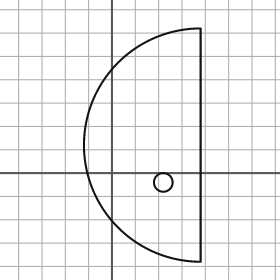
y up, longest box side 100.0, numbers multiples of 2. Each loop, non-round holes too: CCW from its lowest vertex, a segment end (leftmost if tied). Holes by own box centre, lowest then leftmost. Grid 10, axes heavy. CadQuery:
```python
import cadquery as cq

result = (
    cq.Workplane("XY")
    .moveTo(38.0, -38.0)
    .lineTo(38.0, 62.0)
    .threePointArc((-12.0, 12.0), (38.0, -38.0))
    .close()
    .moveTo(22.0, -4.0)
    .circle(4.0)
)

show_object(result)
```